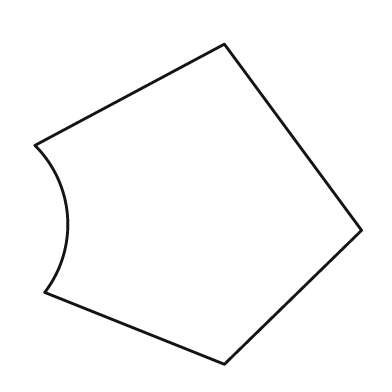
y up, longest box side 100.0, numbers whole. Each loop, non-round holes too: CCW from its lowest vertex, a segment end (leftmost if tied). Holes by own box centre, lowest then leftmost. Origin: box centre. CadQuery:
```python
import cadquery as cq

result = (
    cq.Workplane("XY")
    .moveTo(8.0, -49.0)
    .lineTo(50.0, -8.0)
    .lineTo(8.0, 49.0)
    .lineTo(-50.0, 18.0)
    .threePointArc((-40.0, -4.0), (-47.0, -27.0))
    .close()
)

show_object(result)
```